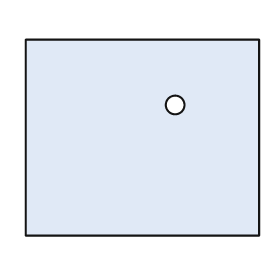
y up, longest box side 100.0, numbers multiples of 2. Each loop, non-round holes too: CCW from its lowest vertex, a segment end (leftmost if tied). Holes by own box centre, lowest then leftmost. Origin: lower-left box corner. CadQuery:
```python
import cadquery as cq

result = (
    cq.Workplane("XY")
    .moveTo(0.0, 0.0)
    .lineTo(100.0, 0.0)
    .lineTo(100.0, 84.0)
    .lineTo(0.0, 84.0)
    .close()
    .moveTo(64.0, 56.0)
    .circle(4.0)
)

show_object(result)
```